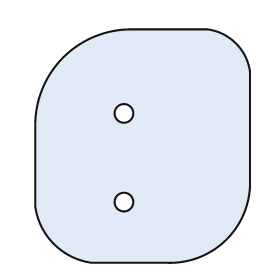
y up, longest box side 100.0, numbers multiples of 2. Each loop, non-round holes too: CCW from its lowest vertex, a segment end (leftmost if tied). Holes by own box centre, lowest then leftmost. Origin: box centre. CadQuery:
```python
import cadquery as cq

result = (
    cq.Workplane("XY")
    .moveTo(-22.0, -50.0)
    .lineTo(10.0, -50.0)
    .threePointArc((36.0, -40.0), (46.0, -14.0))
    .lineTo(46.0, 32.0)
    .threePointArc((40.0, 44.0), (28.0, 50.0))
    .lineTo(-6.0, 50.0)
    .threePointArc((-34.0, 38.0), (-46.0, 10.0))
    .lineTo(-46.0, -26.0)
    .threePointArc((-38.0, -42.0), (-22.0, -50.0))
    .close()
    .moveTo(-8.0, -24.0)
    .circle(4.0)
    .moveTo(-8.0, 14.0)
    .circle(4.0)
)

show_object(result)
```